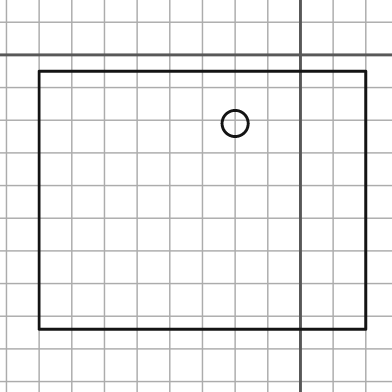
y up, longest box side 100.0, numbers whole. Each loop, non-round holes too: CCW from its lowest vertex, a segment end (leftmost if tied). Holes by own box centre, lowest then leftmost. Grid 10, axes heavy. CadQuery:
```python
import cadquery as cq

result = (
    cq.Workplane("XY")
    .moveTo(-80.0, -84.0)
    .lineTo(20.0, -84.0)
    .lineTo(20.0, -5.0)
    .lineTo(-80.0, -5.0)
    .close()
    .moveTo(-20.0, -21.0)
    .circle(4.0)
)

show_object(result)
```